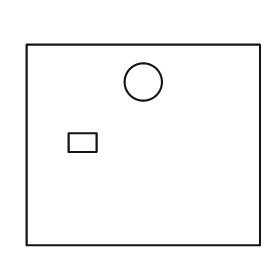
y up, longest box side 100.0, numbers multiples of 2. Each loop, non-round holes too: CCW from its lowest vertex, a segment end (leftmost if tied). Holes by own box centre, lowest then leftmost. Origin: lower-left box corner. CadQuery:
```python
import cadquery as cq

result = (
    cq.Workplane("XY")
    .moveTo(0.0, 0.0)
    .lineTo(100.0, 0.0)
    .lineTo(100.0, 86.0)
    .lineTo(0.0, 86.0)
    .close()
    .moveTo(18.0, 40.0)
    .lineTo(30.0, 40.0)
    .lineTo(30.0, 48.0)
    .lineTo(18.0, 48.0)
    .close()
    .moveTo(50.0, 70.0)
    .circle(8.0)
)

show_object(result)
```